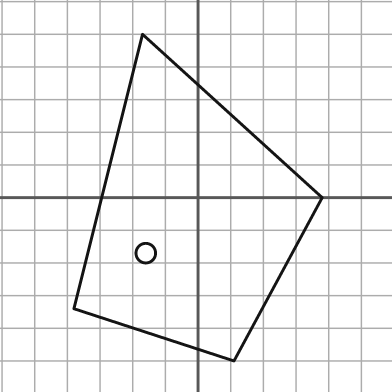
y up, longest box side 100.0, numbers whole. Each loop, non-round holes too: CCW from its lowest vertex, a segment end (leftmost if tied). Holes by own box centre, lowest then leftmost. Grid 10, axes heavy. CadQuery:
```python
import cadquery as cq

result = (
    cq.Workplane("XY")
    .moveTo(11.0, -50.0)
    .lineTo(38.0, 0.0)
    .lineTo(-17.0, 50.0)
    .lineTo(-38.0, -34.0)
    .close()
    .moveTo(-16.0, -17.0)
    .circle(3.0)
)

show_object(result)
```